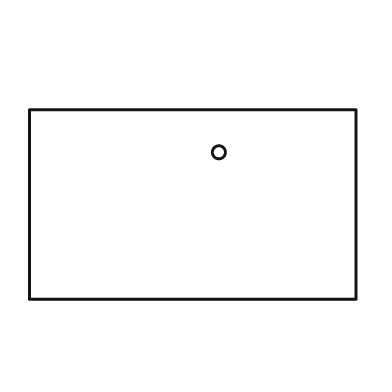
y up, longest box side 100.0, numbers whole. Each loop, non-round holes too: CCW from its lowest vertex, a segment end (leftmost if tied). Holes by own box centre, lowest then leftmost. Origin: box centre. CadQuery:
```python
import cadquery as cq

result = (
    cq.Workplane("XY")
    .moveTo(-50.0, -29.0)
    .lineTo(50.0, -29.0)
    .lineTo(50.0, 29.0)
    .lineTo(-50.0, 29.0)
    .close()
    .moveTo(8.0, 16.0)
    .circle(2.0)
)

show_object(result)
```